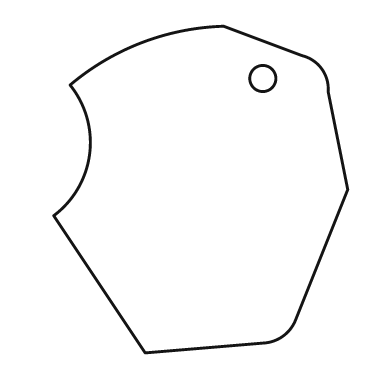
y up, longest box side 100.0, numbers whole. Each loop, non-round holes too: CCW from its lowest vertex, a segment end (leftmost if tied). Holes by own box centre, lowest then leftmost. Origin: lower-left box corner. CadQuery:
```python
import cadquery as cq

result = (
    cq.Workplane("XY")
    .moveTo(28.0, 0.0)
    .lineTo(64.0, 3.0)
    .threePointArc((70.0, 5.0), (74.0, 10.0))
    .lineTo(90.0, 50.0)
    .lineTo(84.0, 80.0)
    .threePointArc((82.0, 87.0), (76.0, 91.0))
    .lineTo(52.0, 100.0)
    .threePointArc((27.0, 95.0), (5.0, 82.0))
    .threePointArc((11.0, 61.0), (0.0, 42.0))
    .close()
    .moveTo(64.0, 84.0)
    .circle(4.0)
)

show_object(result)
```